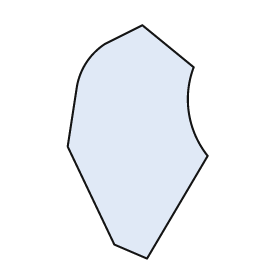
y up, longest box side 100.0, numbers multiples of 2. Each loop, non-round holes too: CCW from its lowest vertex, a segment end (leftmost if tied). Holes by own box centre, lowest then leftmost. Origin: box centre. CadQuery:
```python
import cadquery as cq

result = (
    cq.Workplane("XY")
    .moveTo(4.0, -50.0)
    .lineTo(30.0, -6.0)
    .threePointArc((22.0, 12.0), (24.0, 32.0))
    .lineTo(2.0, 50.0)
    .lineTo(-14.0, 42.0)
    .threePointArc((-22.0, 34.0), (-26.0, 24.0))
    .lineTo(-30.0, -2.0)
    .lineTo(-10.0, -44.0)
    .close()
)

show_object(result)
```